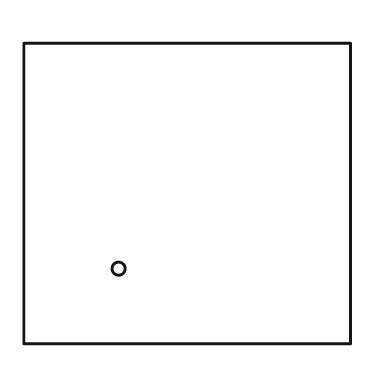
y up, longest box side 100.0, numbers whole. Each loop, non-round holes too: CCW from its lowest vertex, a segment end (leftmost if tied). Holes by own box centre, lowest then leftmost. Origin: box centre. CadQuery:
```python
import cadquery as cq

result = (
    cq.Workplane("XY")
    .moveTo(-50.0, -46.0)
    .lineTo(50.0, -46.0)
    .lineTo(50.0, 46.0)
    .lineTo(-50.0, 46.0)
    .close()
    .moveTo(-21.0, -23.0)
    .circle(2.0)
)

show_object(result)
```